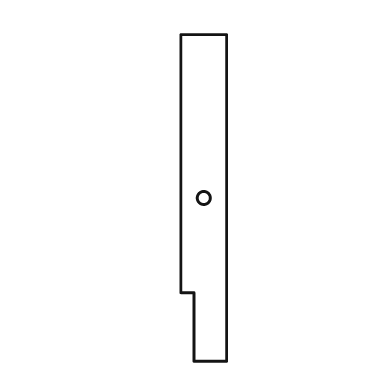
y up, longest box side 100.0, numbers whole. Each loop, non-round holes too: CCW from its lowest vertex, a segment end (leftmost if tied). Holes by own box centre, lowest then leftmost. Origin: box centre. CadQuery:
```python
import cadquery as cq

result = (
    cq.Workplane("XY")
    .moveTo(-3.0, -50.0)
    .lineTo(7.0, -50.0)
    .lineTo(7.0, 50.0)
    .lineTo(-7.0, 50.0)
    .lineTo(-7.0, -29.0)
    .lineTo(-3.0, -29.0)
    .close()
    .moveTo(0.0, 0.0)
    .circle(2.0)
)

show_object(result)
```